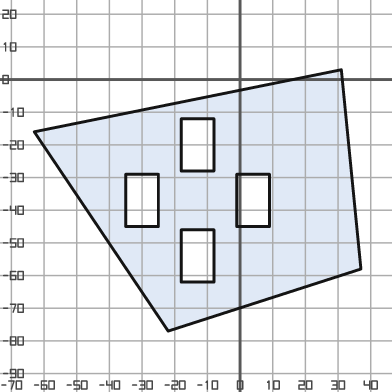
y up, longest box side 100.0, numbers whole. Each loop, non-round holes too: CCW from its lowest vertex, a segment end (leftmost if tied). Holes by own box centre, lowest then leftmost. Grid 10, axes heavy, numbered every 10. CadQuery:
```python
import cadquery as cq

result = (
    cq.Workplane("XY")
    .moveTo(-22.0, -77.0)
    .lineTo(37.0, -58.0)
    .lineTo(31.0, 3.0)
    .lineTo(-63.0, -16.0)
    .close()
    .moveTo(-18.0, -62.0)
    .lineTo(-8.0, -62.0)
    .lineTo(-8.0, -46.0)
    .lineTo(-18.0, -46.0)
    .close()
    .moveTo(-35.0, -45.0)
    .lineTo(-25.0, -45.0)
    .lineTo(-25.0, -29.0)
    .lineTo(-35.0, -29.0)
    .close()
    .moveTo(-1.0, -45.0)
    .lineTo(9.0, -45.0)
    .lineTo(9.0, -29.0)
    .lineTo(-1.0, -29.0)
    .close()
    .moveTo(-18.0, -28.0)
    .lineTo(-8.0, -28.0)
    .lineTo(-8.0, -12.0)
    .lineTo(-18.0, -12.0)
    .close()
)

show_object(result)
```